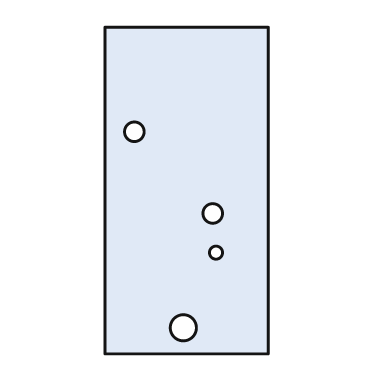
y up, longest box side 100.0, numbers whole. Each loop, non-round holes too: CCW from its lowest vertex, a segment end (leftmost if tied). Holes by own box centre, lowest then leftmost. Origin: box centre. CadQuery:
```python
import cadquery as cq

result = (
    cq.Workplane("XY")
    .moveTo(-25.0, -50.0)
    .lineTo(25.0, -50.0)
    .lineTo(25.0, 50.0)
    .lineTo(-25.0, 50.0)
    .close()
    .moveTo(-1.0, -42.0)
    .circle(4.0)
    .moveTo(9.0, -19.0)
    .circle(2.0)
    .moveTo(8.0, -7.0)
    .circle(3.0)
    .moveTo(-16.0, 18.0)
    .circle(3.0)
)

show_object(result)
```